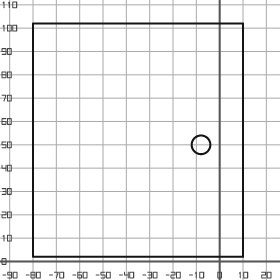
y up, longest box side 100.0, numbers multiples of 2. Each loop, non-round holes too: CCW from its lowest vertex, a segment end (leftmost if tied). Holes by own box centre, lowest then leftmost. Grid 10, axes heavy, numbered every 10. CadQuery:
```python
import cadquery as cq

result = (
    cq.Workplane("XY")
    .moveTo(-80.0, 2.0)
    .lineTo(10.0, 2.0)
    .lineTo(10.0, 102.0)
    .lineTo(-80.0, 102.0)
    .close()
    .moveTo(-8.0, 50.0)
    .circle(4.0)
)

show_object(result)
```